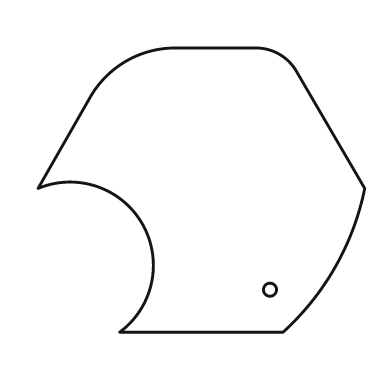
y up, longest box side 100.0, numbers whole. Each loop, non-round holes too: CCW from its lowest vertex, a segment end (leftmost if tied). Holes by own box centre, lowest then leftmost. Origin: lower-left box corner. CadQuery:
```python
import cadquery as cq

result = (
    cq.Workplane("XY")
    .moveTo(25.0, 0.0)
    .lineTo(75.0, 0.0)
    .threePointArc((91.0, 20.0), (100.0, 44.0))
    .lineTo(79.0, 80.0)
    .threePointArc((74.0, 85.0), (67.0, 87.0))
    .lineTo(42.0, 87.0)
    .threePointArc((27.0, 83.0), (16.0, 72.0))
    .lineTo(0.0, 44.0)
    .threePointArc((32.0, 33.0), (25.0, 0.0))
    .close()
    .moveTo(71.0, 13.0)
    .circle(2.0)
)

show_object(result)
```